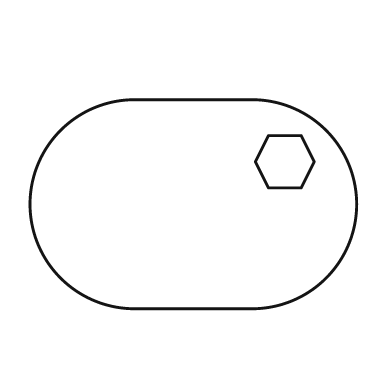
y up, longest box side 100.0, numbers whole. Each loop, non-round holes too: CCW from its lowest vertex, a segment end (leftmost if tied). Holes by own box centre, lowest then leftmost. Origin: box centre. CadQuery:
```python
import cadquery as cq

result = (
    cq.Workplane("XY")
    .moveTo(-18.0, -32.0)
    .lineTo(18.0, -32.0)
    .threePointArc((50.0, 0.0), (18.0, 32.0))
    .lineTo(-18.0, 32.0)
    .threePointArc((-50.0, 0.0), (-18.0, -32.0))
    .close()
    .moveTo(23.0, 5.0)
    .lineTo(33.0, 5.0)
    .lineTo(37.0, 13.0)
    .lineTo(33.0, 21.0)
    .lineTo(23.0, 21.0)
    .lineTo(19.0, 13.0)
    .close()
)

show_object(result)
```